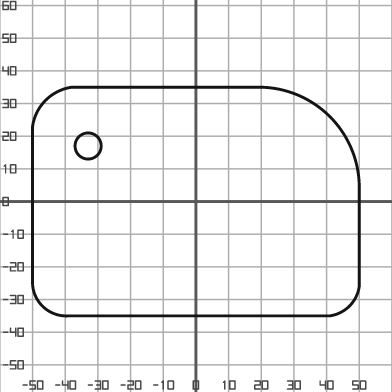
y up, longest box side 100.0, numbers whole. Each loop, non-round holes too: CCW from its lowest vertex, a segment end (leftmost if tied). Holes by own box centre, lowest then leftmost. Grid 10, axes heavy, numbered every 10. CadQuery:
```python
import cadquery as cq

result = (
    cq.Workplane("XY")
    .moveTo(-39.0, -35.0)
    .lineTo(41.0, -35.0)
    .threePointArc((47.0, -32.0), (50.0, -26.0))
    .lineTo(50.0, 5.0)
    .threePointArc((41.0, 26.0), (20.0, 35.0))
    .lineTo(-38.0, 35.0)
    .threePointArc((-46.0, 31.0), (-50.0, 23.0))
    .lineTo(-50.0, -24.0)
    .threePointArc((-47.0, -32.0), (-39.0, -35.0))
    .close()
    .moveTo(-33.0, 17.0)
    .circle(4.0)
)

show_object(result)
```